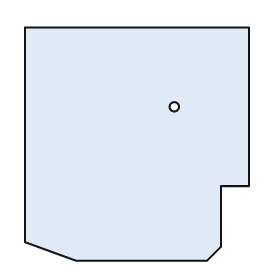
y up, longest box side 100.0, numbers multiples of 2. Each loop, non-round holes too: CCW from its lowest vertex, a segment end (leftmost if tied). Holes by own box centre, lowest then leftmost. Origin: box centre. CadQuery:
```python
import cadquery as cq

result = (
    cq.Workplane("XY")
    .moveTo(-26.0, -50.0)
    .lineTo(30.0, -50.0)
    .lineTo(36.0, -44.0)
    .lineTo(36.0, -18.0)
    .lineTo(48.0, -18.0)
    .lineTo(48.0, 50.0)
    .lineTo(-48.0, 50.0)
    .lineTo(-48.0, -42.0)
    .close()
    .moveTo(16.0, 16.0)
    .circle(2.0)
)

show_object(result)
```